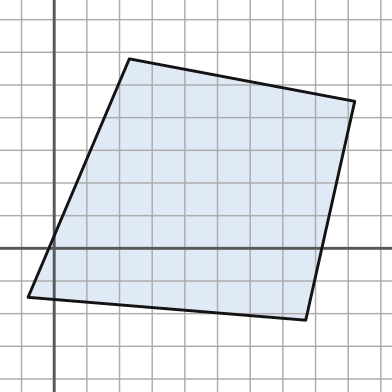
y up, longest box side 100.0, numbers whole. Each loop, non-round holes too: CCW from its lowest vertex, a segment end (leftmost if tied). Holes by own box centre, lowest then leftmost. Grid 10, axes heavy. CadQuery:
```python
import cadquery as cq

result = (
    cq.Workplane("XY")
    .moveTo(77.0, -22.0)
    .lineTo(92.0, 45.0)
    .lineTo(23.0, 58.0)
    .lineTo(-8.0, -15.0)
    .close()
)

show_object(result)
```